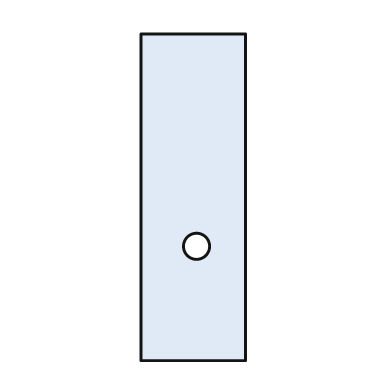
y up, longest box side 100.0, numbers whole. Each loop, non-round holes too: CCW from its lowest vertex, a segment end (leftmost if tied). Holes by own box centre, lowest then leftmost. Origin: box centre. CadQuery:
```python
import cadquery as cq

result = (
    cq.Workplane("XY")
    .moveTo(-16.0, -50.0)
    .lineTo(16.0, -50.0)
    .lineTo(16.0, 50.0)
    .lineTo(-16.0, 50.0)
    .close()
    .moveTo(1.0, -15.0)
    .circle(4.0)
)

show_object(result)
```